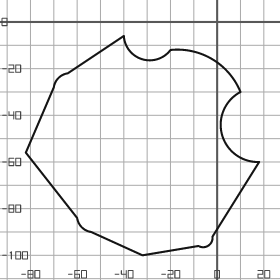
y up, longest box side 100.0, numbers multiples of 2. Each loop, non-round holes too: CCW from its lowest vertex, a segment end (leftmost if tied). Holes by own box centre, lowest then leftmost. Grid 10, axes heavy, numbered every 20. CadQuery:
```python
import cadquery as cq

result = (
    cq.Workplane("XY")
    .moveTo(-32.0, -100.0)
    .lineTo(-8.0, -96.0)
    .threePointArc((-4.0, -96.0), (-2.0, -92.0))
    .lineTo(18.0, -60.0)
    .threePointArc((2.0, -48.0), (10.0, -30.0))
    .threePointArc((-2.0, -16.0), (-20.0, -12.0))
    .threePointArc((-32.0, -16.0), (-40.0, -6.0))
    .lineTo(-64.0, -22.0)
    .threePointArc((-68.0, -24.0), (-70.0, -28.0))
    .lineTo(-82.0, -56.0)
    .lineTo(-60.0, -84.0)
    .threePointArc((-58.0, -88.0), (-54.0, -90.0))
    .close()
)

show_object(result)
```